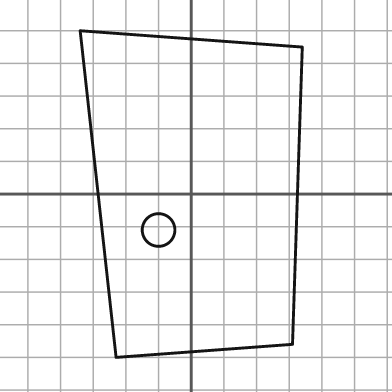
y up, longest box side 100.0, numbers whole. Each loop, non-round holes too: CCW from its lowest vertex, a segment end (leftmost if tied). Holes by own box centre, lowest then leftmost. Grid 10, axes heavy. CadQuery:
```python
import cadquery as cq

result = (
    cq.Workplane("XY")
    .moveTo(-23.0, -50.0)
    .lineTo(31.0, -46.0)
    .lineTo(34.0, 45.0)
    .lineTo(-34.0, 50.0)
    .close()
    .moveTo(-10.0, -11.0)
    .circle(5.0)
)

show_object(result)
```